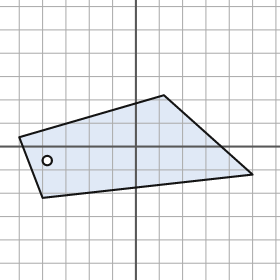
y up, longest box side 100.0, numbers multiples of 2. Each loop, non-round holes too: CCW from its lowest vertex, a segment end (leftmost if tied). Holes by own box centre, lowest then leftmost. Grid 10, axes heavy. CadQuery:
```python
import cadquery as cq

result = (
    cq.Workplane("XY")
    .moveTo(-40.0, -22.0)
    .lineTo(50.0, -12.0)
    .lineTo(12.0, 22.0)
    .lineTo(-50.0, 4.0)
    .close()
    .moveTo(-38.0, -6.0)
    .circle(2.0)
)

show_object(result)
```